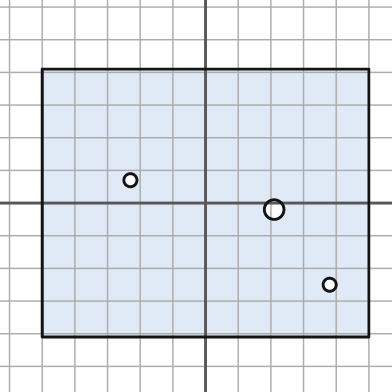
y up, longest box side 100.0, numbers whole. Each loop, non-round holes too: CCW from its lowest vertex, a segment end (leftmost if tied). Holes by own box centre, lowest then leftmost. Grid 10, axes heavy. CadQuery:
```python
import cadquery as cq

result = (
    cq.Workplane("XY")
    .moveTo(-50.0, -41.0)
    .lineTo(50.0, -41.0)
    .lineTo(50.0, 41.0)
    .lineTo(-50.0, 41.0)
    .close()
    .moveTo(38.0, -25.0)
    .circle(2.0)
    .moveTo(21.0, -2.0)
    .circle(3.0)
    .moveTo(-23.0, 7.0)
    .circle(2.0)
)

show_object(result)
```